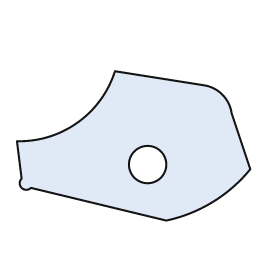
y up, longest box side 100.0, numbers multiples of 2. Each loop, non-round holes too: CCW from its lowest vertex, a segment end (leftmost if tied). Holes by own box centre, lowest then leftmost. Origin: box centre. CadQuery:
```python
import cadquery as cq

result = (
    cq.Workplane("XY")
    .moveTo(14.0, -32.0)
    .threePointArc((34.0, -24.0), (50.0, -10.0))
    .lineTo(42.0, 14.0)
    .threePointArc((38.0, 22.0), (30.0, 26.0))
    .lineTo(-8.0, 32.0)
    .threePointArc((-24.0, 10.0), (-50.0, 2.0))
    .lineTo(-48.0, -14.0)
    .threePointArc((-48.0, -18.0), (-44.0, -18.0))
    .close()
    .moveTo(6.0, -8.0)
    .circle(8.0)
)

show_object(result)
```